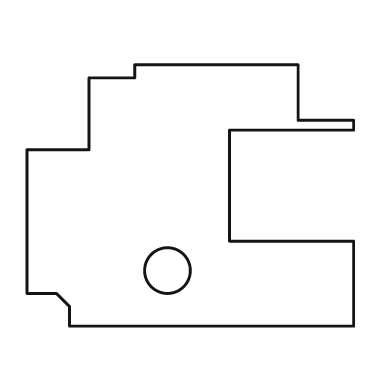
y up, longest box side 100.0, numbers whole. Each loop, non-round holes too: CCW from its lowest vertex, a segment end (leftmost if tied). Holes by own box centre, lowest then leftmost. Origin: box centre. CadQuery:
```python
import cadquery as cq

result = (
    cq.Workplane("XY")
    .moveTo(-37.0, -40.0)
    .lineTo(50.0, -40.0)
    .lineTo(50.0, -14.0)
    .lineTo(12.0, -14.0)
    .lineTo(12.0, 20.0)
    .lineTo(50.0, 20.0)
    .lineTo(50.0, 23.0)
    .lineTo(33.0, 23.0)
    .lineTo(33.0, 40.0)
    .lineTo(-17.0, 40.0)
    .lineTo(-17.0, 36.0)
    .lineTo(-31.0, 36.0)
    .lineTo(-31.0, 14.0)
    .lineTo(-50.0, 14.0)
    .lineTo(-50.0, -30.0)
    .lineTo(-41.0, -30.0)
    .lineTo(-37.0, -34.0)
    .close()
    .moveTo(-7.0, -23.0)
    .circle(7.0)
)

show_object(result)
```